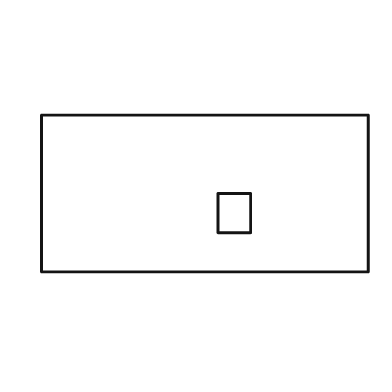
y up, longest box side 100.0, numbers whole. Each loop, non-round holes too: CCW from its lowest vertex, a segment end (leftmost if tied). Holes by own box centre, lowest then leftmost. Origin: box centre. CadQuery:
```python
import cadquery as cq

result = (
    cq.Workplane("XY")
    .moveTo(-50.0, -24.0)
    .lineTo(50.0, -24.0)
    .lineTo(50.0, 24.0)
    .lineTo(-50.0, 24.0)
    .close()
    .moveTo(4.0, -12.0)
    .lineTo(14.0, -12.0)
    .lineTo(14.0, 0.0)
    .lineTo(4.0, 0.0)
    .close()
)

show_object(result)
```